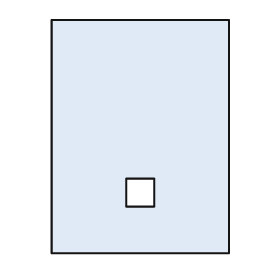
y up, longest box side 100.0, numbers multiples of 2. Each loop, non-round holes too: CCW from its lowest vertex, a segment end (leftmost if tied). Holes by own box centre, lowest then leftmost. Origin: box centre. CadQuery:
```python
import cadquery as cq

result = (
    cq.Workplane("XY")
    .moveTo(-38.0, -50.0)
    .lineTo(38.0, -50.0)
    .lineTo(38.0, 50.0)
    .lineTo(-38.0, 50.0)
    .close()
    .moveTo(-6.0, -30.0)
    .lineTo(6.0, -30.0)
    .lineTo(6.0, -18.0)
    .lineTo(-6.0, -18.0)
    .close()
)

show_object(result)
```